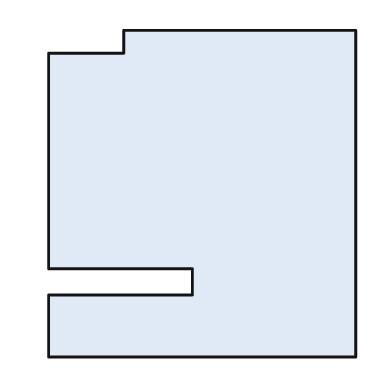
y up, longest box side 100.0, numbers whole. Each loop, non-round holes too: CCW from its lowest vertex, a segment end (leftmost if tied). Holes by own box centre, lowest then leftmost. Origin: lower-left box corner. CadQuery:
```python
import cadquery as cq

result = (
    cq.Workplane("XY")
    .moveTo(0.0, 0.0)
    .lineTo(94.0, 0.0)
    .lineTo(94.0, 100.0)
    .lineTo(23.0, 100.0)
    .lineTo(23.0, 93.0)
    .lineTo(0.0, 93.0)
    .lineTo(0.0, 27.0)
    .lineTo(44.0, 27.0)
    .lineTo(44.0, 19.0)
    .lineTo(0.0, 19.0)
    .close()
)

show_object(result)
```